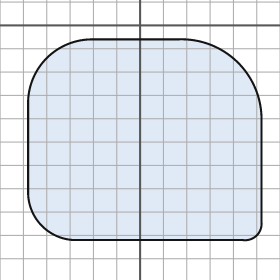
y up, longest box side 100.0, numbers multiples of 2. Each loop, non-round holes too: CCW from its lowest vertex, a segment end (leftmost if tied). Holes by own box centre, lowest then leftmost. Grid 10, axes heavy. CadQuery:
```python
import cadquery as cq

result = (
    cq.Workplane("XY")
    .moveTo(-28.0, -92.0)
    .lineTo(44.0, -92.0)
    .threePointArc((50.0, -90.0), (52.0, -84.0))
    .lineTo(52.0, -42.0)
    .threePointArc((42.0, -16.0), (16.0, -6.0))
    .lineTo(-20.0, -6.0)
    .threePointArc((-40.0, -14.0), (-48.0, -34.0))
    .lineTo(-48.0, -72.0)
    .threePointArc((-42.0, -86.0), (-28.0, -92.0))
    .close()
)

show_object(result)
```